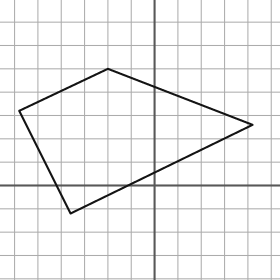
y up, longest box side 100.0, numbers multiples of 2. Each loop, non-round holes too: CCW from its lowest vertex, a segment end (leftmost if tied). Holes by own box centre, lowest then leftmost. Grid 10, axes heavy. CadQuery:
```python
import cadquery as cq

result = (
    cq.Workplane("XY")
    .moveTo(-36.0, -12.0)
    .lineTo(42.0, 26.0)
    .lineTo(-20.0, 50.0)
    .lineTo(-58.0, 32.0)
    .close()
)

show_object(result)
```